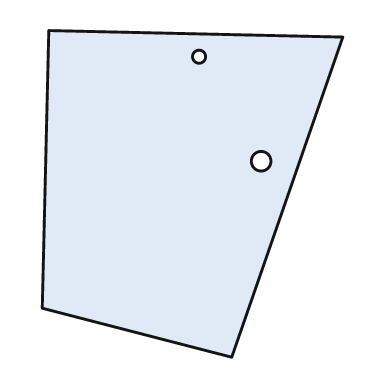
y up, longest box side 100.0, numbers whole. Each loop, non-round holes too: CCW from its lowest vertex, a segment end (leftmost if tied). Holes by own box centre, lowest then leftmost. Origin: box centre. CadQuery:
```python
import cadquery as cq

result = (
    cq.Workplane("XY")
    .moveTo(12.0, -50.0)
    .lineTo(46.0, 48.0)
    .lineTo(-44.0, 50.0)
    .lineTo(-46.0, -35.0)
    .close()
    .moveTo(21.0, 10.0)
    .circle(3.0)
    .moveTo(2.0, 42.0)
    .circle(2.0)
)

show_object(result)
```